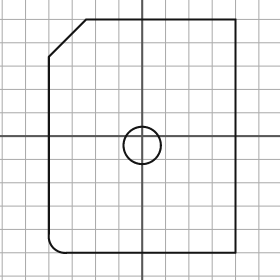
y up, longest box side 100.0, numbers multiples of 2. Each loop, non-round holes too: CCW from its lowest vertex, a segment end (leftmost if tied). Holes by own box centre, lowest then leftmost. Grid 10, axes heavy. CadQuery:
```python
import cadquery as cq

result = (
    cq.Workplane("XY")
    .moveTo(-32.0, -50.0)
    .lineTo(40.0, -50.0)
    .lineTo(40.0, 50.0)
    .lineTo(-24.0, 50.0)
    .lineTo(-40.0, 34.0)
    .lineTo(-40.0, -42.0)
    .threePointArc((-38.0, -48.0), (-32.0, -50.0))
    .close()
    .moveTo(0.0, -4.0)
    .circle(8.0)
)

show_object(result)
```